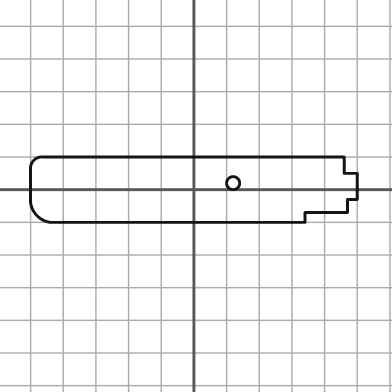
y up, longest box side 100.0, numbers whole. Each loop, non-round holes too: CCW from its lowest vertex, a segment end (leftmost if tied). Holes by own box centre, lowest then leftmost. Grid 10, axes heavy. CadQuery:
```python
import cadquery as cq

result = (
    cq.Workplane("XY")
    .moveTo(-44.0, -10.0)
    .lineTo(34.0, -10.0)
    .lineTo(34.0, -7.0)
    .lineTo(47.0, -7.0)
    .lineTo(47.0, -3.0)
    .lineTo(50.0, -3.0)
    .lineTo(50.0, 5.0)
    .lineTo(46.0, 5.0)
    .lineTo(46.0, 10.0)
    .lineTo(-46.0, 10.0)
    .threePointArc((-49.0, 9.0), (-50.0, 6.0))
    .lineTo(-50.0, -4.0)
    .threePointArc((-48.0, -8.0), (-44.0, -10.0))
    .close()
    .moveTo(12.0, 2.0)
    .circle(2.0)
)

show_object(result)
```